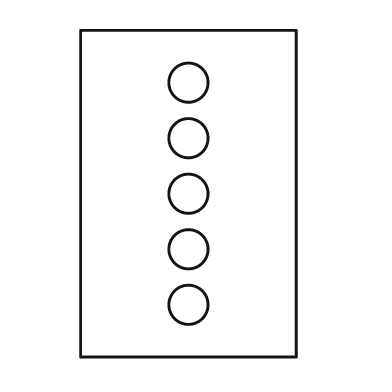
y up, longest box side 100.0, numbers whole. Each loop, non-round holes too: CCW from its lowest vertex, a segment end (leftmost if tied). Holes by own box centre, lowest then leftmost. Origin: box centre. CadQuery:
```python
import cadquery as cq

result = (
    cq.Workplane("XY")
    .moveTo(-33.0, -50.0)
    .lineTo(33.0, -50.0)
    .lineTo(33.0, 50.0)
    .lineTo(-33.0, 50.0)
    .close()
    .moveTo(0.0, -34.0)
    .circle(6.0)
    .moveTo(0.0, -17.0)
    .circle(6.0)
    .moveTo(0.0, 0.0)
    .circle(6.0)
    .moveTo(0.0, 17.0)
    .circle(6.0)
    .moveTo(0.0, 34.0)
    .circle(6.0)
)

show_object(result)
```